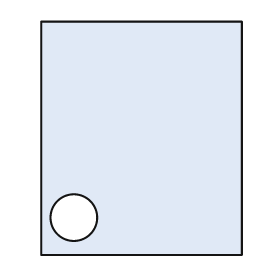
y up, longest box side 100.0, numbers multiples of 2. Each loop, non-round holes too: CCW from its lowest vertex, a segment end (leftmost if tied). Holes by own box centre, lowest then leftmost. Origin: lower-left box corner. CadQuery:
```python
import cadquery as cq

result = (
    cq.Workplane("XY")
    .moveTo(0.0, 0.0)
    .lineTo(86.0, 0.0)
    .lineTo(86.0, 100.0)
    .lineTo(0.0, 100.0)
    .close()
    .moveTo(14.0, 16.0)
    .circle(10.0)
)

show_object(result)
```